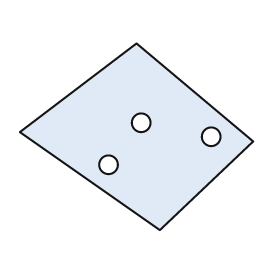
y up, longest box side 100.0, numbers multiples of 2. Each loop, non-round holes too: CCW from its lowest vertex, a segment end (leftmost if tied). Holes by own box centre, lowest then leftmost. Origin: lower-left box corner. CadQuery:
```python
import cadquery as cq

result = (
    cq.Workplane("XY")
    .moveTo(60.0, 0.0)
    .lineTo(100.0, 38.0)
    .lineTo(50.0, 80.0)
    .lineTo(0.0, 42.0)
    .close()
    .moveTo(38.0, 28.0)
    .circle(4.0)
    .moveTo(82.0, 40.0)
    .circle(4.0)
    .moveTo(52.0, 46.0)
    .circle(4.0)
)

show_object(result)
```